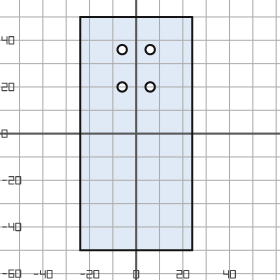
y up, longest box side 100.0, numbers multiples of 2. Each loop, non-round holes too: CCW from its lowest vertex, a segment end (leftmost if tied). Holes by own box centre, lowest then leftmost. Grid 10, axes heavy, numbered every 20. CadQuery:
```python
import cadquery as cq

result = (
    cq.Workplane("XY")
    .moveTo(-24.0, -50.0)
    .lineTo(24.0, -50.0)
    .lineTo(24.0, 50.0)
    .lineTo(-24.0, 50.0)
    .close()
    .moveTo(-6.0, 20.0)
    .circle(2.0)
    .moveTo(6.0, 20.0)
    .circle(2.0)
    .moveTo(-6.0, 36.0)
    .circle(2.0)
    .moveTo(6.0, 36.0)
    .circle(2.0)
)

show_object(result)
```